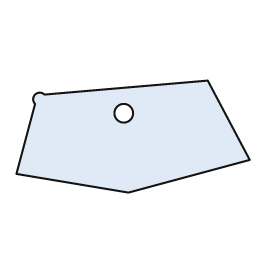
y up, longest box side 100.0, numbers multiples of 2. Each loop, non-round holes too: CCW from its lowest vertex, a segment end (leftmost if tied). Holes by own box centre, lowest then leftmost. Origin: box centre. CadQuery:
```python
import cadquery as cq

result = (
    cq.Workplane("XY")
    .moveTo(-2.0, -24.0)
    .lineTo(50.0, -10.0)
    .lineTo(32.0, 24.0)
    .lineTo(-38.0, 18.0)
    .threePointArc((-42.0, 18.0), (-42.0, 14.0))
    .lineTo(-50.0, -16.0)
    .close()
    .moveTo(-4.0, 10.0)
    .circle(4.0)
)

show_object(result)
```